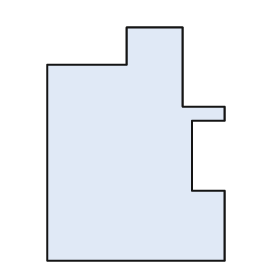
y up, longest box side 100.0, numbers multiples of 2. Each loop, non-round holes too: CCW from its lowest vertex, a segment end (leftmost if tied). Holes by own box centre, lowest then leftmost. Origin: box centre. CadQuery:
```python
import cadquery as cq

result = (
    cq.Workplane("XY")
    .moveTo(-38.0, -50.0)
    .lineTo(38.0, -50.0)
    .lineTo(38.0, -20.0)
    .lineTo(24.0, -20.0)
    .lineTo(24.0, 10.0)
    .lineTo(38.0, 10.0)
    .lineTo(38.0, 16.0)
    .lineTo(20.0, 16.0)
    .lineTo(20.0, 50.0)
    .lineTo(-4.0, 50.0)
    .lineTo(-4.0, 34.0)
    .lineTo(-38.0, 34.0)
    .close()
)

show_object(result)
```